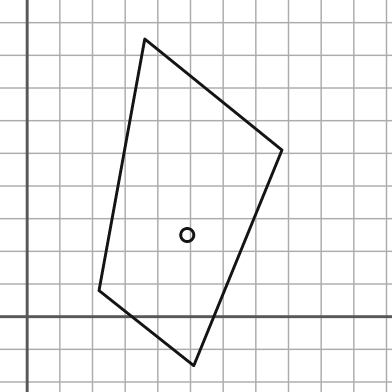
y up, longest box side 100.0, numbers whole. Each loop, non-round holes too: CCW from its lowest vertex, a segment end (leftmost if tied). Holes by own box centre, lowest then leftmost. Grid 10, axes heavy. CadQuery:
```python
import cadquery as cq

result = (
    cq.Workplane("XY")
    .moveTo(51.0, -15.0)
    .lineTo(78.0, 51.0)
    .lineTo(36.0, 85.0)
    .lineTo(22.0, 8.0)
    .close()
    .moveTo(49.0, 25.0)
    .circle(2.0)
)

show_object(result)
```